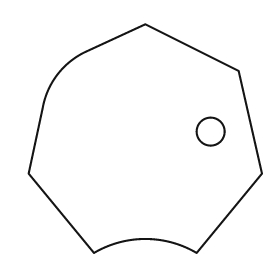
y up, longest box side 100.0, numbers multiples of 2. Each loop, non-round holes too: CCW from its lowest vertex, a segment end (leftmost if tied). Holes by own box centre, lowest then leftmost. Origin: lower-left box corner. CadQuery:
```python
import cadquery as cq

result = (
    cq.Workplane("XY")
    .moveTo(28.0, 0.0)
    .threePointArc((50.0, 6.0), (72.0, 0.0))
    .lineTo(100.0, 34.0)
    .lineTo(90.0, 78.0)
    .lineTo(50.0, 98.0)
    .lineTo(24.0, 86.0)
    .threePointArc((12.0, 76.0), (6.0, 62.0))
    .lineTo(0.0, 34.0)
    .close()
    .moveTo(78.0, 52.0)
    .circle(6.0)
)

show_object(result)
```